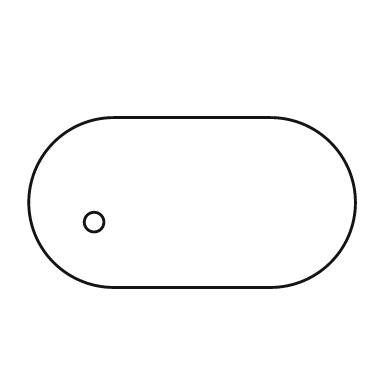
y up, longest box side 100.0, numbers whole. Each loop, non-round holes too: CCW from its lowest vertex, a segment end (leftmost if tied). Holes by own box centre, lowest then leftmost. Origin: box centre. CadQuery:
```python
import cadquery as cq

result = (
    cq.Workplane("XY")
    .moveTo(-24.0, -26.0)
    .lineTo(24.0, -26.0)
    .threePointArc((50.0, 0.0), (24.0, 26.0))
    .lineTo(-24.0, 26.0)
    .threePointArc((-50.0, 0.0), (-24.0, -26.0))
    .close()
    .moveTo(-30.0, -6.0)
    .circle(3.0)
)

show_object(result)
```